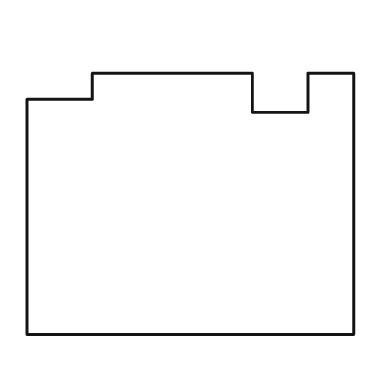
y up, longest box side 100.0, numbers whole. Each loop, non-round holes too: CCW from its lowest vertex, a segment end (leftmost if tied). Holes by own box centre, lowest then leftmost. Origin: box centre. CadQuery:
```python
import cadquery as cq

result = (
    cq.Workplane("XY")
    .moveTo(-50.0, -40.0)
    .lineTo(50.0, -40.0)
    .lineTo(50.0, 40.0)
    .lineTo(36.0, 40.0)
    .lineTo(36.0, 28.0)
    .lineTo(19.0, 28.0)
    .lineTo(19.0, 40.0)
    .lineTo(-30.0, 40.0)
    .lineTo(-30.0, 32.0)
    .lineTo(-50.0, 32.0)
    .close()
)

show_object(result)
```